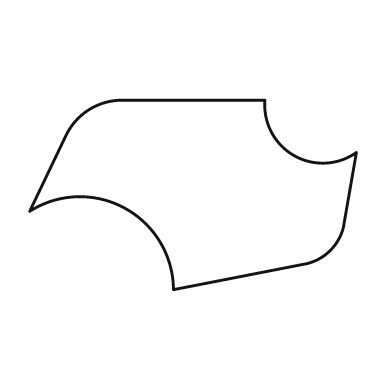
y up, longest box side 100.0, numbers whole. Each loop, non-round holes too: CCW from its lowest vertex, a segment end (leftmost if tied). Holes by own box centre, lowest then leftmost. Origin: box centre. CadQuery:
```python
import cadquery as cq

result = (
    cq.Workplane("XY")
    .moveTo(-6.0, -29.0)
    .lineTo(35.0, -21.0)
    .threePointArc((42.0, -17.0), (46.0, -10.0))
    .lineTo(50.0, 13.0)
    .threePointArc((31.0, 12.0), (22.0, 29.0))
    .lineTo(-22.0, 29.0)
    .threePointArc((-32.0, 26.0), (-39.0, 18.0))
    .lineTo(-50.0, -5.0)
    .threePointArc((-21.0, -4.0), (-6.0, -29.0))
    .close()
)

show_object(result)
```